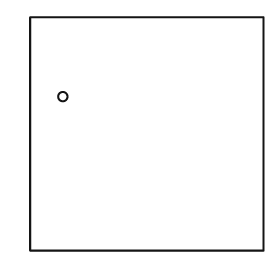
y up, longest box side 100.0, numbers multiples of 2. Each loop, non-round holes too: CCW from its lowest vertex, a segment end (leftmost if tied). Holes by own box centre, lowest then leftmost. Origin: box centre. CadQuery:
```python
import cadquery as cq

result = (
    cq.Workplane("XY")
    .moveTo(-50.0, -50.0)
    .lineTo(50.0, -50.0)
    .lineTo(50.0, 50.0)
    .lineTo(-50.0, 50.0)
    .close()
    .moveTo(-36.0, 16.0)
    .circle(2.0)
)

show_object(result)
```